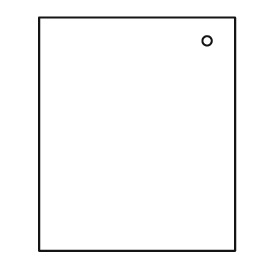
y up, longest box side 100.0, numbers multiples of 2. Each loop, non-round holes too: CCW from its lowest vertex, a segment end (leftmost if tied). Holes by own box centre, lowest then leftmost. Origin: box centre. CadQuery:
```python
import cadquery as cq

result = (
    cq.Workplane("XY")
    .moveTo(-42.0, -50.0)
    .lineTo(42.0, -50.0)
    .lineTo(42.0, 50.0)
    .lineTo(-42.0, 50.0)
    .close()
    .moveTo(30.0, 40.0)
    .circle(2.0)
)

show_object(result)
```